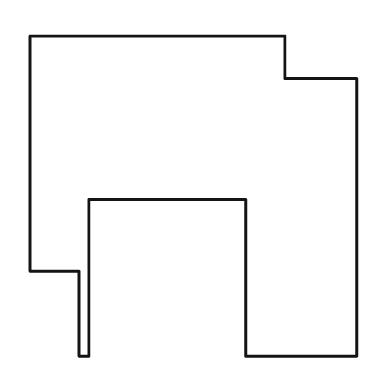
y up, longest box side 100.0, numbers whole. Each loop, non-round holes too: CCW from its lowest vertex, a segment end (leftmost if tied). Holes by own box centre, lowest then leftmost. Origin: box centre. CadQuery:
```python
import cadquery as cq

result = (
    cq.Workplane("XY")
    .moveTo(-35.0, -49.0)
    .lineTo(-32.0, -49.0)
    .lineTo(-32.0, -1.0)
    .lineTo(16.0, -1.0)
    .lineTo(16.0, -49.0)
    .lineTo(50.0, -49.0)
    .lineTo(50.0, 36.0)
    .lineTo(28.0, 36.0)
    .lineTo(28.0, 49.0)
    .lineTo(-50.0, 49.0)
    .lineTo(-50.0, -23.0)
    .lineTo(-35.0, -23.0)
    .close()
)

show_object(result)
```